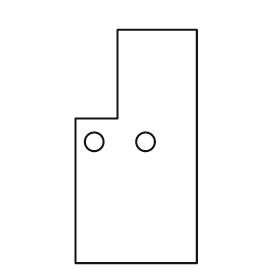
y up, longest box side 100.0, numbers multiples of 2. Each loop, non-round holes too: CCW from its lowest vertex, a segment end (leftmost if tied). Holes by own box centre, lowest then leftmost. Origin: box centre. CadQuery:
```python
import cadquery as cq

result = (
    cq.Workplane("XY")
    .moveTo(-26.0, -50.0)
    .lineTo(26.0, -50.0)
    .lineTo(26.0, 50.0)
    .lineTo(-8.0, 50.0)
    .lineTo(-8.0, 12.0)
    .lineTo(-26.0, 12.0)
    .close()
    .moveTo(-18.0, 2.0)
    .circle(4.0)
    .moveTo(4.0, 2.0)
    .circle(4.0)
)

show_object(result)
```